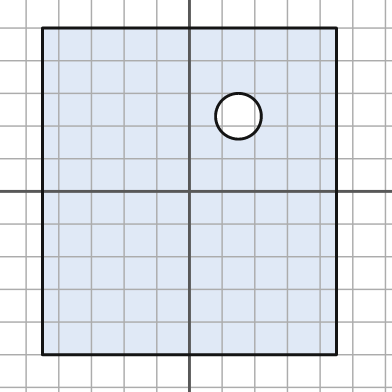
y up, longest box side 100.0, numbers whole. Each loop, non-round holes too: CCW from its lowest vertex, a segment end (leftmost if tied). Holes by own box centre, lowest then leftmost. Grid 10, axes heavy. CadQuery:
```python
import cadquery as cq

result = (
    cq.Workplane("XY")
    .moveTo(-45.0, -50.0)
    .lineTo(45.0, -50.0)
    .lineTo(45.0, 50.0)
    .lineTo(-45.0, 50.0)
    .close()
    .moveTo(15.0, 23.0)
    .circle(7.0)
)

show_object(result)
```